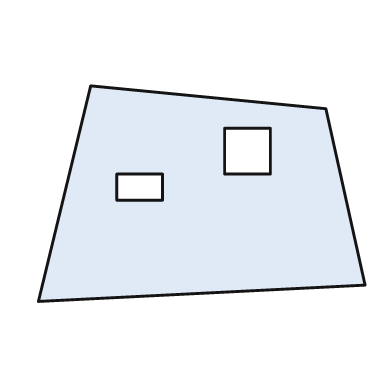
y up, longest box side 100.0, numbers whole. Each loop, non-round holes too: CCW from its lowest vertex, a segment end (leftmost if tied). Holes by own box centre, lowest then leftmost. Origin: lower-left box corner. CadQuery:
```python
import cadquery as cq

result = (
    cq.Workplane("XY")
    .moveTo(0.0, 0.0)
    .lineTo(100.0, 5.0)
    .lineTo(88.0, 59.0)
    .lineTo(16.0, 66.0)
    .close()
    .moveTo(24.0, 31.0)
    .lineTo(38.0, 31.0)
    .lineTo(38.0, 39.0)
    .lineTo(24.0, 39.0)
    .close()
    .moveTo(57.0, 39.0)
    .lineTo(71.0, 39.0)
    .lineTo(71.0, 53.0)
    .lineTo(57.0, 53.0)
    .close()
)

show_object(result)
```